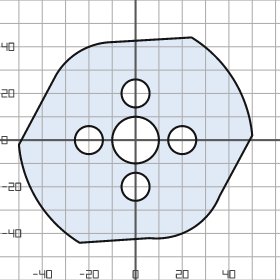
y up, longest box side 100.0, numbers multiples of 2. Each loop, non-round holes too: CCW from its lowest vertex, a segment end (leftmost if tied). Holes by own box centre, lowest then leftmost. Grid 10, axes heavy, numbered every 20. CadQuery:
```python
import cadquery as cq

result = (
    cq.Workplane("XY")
    .moveTo(-24.0, -44.0)
    .lineTo(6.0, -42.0)
    .threePointArc((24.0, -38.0), (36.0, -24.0))
    .lineTo(50.0, 2.0)
    .threePointArc((42.0, 26.0), (24.0, 44.0))
    .lineTo(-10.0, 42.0)
    .threePointArc((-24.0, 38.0), (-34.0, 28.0))
    .lineTo(-50.0, -2.0)
    .threePointArc((-42.0, -26.0), (-24.0, -44.0))
    .close()
    .moveTo(0.0, -20.0)
    .circle(6.0)
    .moveTo(-20.0, 0.0)
    .circle(6.0)
    .moveTo(0.0, 0.0)
    .circle(10.0)
    .moveTo(20.0, 0.0)
    .circle(6.0)
    .moveTo(0.0, 20.0)
    .circle(6.0)
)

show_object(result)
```